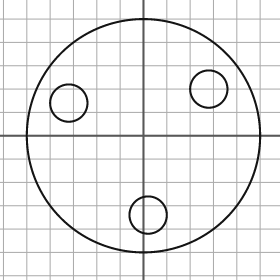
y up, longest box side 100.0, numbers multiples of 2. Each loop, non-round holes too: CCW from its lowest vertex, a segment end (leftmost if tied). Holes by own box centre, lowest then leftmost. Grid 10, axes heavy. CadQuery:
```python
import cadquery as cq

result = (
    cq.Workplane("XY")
    .moveTo(0.0, 0.0)
    .circle(50.0)
    .moveTo(2.0, -34.0)
    .circle(8.0)
    .moveTo(-32.0, 14.0)
    .circle(8.0)
    .moveTo(28.0, 20.0)
    .circle(8.0)
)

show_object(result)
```